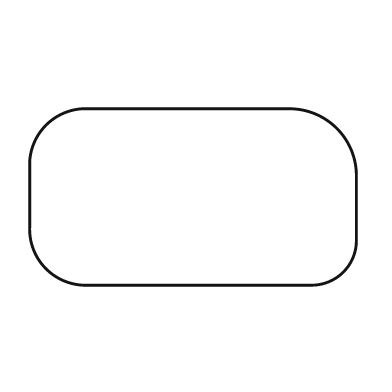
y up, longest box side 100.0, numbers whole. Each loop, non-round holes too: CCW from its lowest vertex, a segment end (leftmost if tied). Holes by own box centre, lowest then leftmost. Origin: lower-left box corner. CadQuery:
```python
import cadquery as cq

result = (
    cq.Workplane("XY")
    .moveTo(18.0, 0.0)
    .lineTo(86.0, 0.0)
    .threePointArc((96.0, 4.0), (100.0, 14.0))
    .lineTo(100.0, 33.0)
    .threePointArc((94.0, 48.0), (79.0, 54.0))
    .lineTo(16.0, 54.0)
    .threePointArc((5.0, 49.0), (0.0, 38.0))
    .lineTo(0.0, 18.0)
    .threePointArc((5.0, 5.0), (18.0, 0.0))
    .close()
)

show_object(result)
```